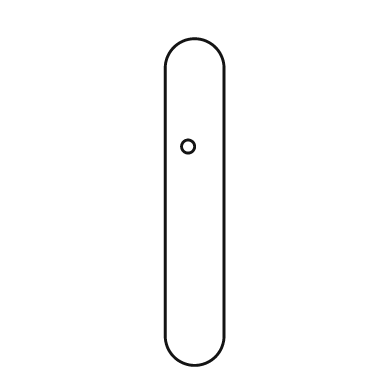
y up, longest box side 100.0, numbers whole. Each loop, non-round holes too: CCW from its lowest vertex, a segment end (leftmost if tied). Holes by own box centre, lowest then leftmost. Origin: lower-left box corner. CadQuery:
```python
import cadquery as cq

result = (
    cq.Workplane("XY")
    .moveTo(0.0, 9.0)
    .threePointArc((9.0, 0.0), (18.0, 9.0))
    .lineTo(18.0, 91.0)
    .threePointArc((9.0, 100.0), (0.0, 91.0))
    .close()
    .moveTo(7.0, 67.0)
    .circle(2.0)
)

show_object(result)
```